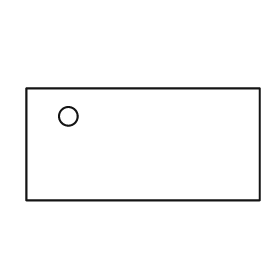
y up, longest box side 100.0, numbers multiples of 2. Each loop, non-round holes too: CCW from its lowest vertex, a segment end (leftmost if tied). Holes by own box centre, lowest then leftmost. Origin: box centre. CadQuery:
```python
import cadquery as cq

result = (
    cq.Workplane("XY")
    .moveTo(-50.0, -24.0)
    .lineTo(50.0, -24.0)
    .lineTo(50.0, 24.0)
    .lineTo(-50.0, 24.0)
    .close()
    .moveTo(-32.0, 12.0)
    .circle(4.0)
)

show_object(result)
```